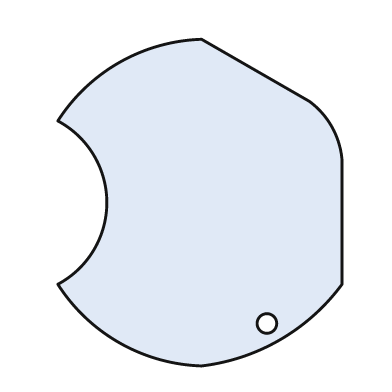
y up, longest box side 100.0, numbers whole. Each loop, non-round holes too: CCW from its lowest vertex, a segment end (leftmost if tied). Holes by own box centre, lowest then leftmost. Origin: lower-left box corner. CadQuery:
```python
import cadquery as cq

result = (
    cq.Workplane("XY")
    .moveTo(44.0, 0.0)
    .threePointArc((68.0, 8.0), (87.0, 25.0))
    .lineTo(87.0, 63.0)
    .threePointArc((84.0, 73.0), (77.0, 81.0))
    .lineTo(44.0, 100.0)
    .threePointArc((19.0, 93.0), (0.0, 75.0))
    .threePointArc((15.0, 50.0), (0.0, 25.0))
    .threePointArc((19.0, 7.0), (44.0, 0.0))
    .close()
    .moveTo(64.0, 13.0)
    .circle(3.0)
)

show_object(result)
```